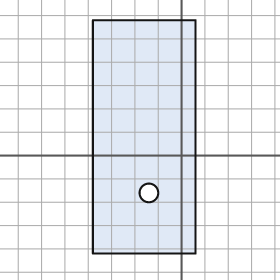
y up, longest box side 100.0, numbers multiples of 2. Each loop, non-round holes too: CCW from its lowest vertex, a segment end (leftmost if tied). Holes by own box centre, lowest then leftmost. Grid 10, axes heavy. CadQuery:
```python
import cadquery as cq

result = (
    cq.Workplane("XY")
    .moveTo(-38.0, -42.0)
    .lineTo(6.0, -42.0)
    .lineTo(6.0, 58.0)
    .lineTo(-38.0, 58.0)
    .close()
    .moveTo(-14.0, -16.0)
    .circle(4.0)
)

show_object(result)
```